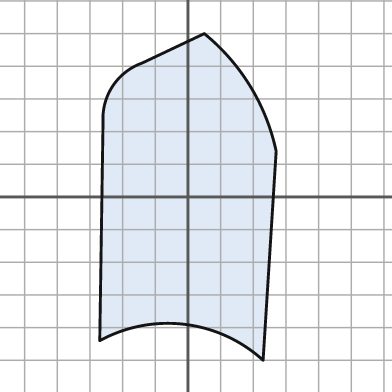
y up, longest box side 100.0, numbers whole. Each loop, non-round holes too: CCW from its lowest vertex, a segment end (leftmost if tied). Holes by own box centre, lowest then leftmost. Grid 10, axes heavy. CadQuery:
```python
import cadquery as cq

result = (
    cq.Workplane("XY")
    .moveTo(23.0, -50.0)
    .lineTo(27.0, 14.0)
    .threePointArc((19.0, 34.0), (5.0, 50.0))
    .lineTo(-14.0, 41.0)
    .threePointArc((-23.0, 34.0), (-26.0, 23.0))
    .lineTo(-27.0, -44.0)
    .threePointArc((-1.0, -39.0), (23.0, -50.0))
    .close()
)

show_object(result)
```